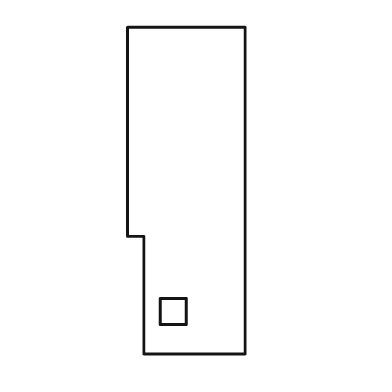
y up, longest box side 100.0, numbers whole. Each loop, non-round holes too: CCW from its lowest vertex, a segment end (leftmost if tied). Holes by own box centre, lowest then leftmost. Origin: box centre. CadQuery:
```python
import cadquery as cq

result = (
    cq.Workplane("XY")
    .moveTo(-13.0, -50.0)
    .lineTo(18.0, -50.0)
    .lineTo(18.0, 50.0)
    .lineTo(-18.0, 50.0)
    .lineTo(-18.0, -14.0)
    .lineTo(-13.0, -14.0)
    .close()
    .moveTo(-8.0, -41.0)
    .lineTo(0.0, -41.0)
    .lineTo(0.0, -33.0)
    .lineTo(-8.0, -33.0)
    .close()
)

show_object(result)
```